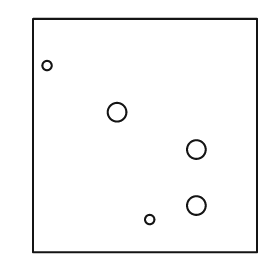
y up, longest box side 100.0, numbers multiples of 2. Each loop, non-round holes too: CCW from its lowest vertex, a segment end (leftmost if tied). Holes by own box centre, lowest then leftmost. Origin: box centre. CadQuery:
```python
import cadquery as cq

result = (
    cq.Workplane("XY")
    .moveTo(-48.0, -50.0)
    .lineTo(48.0, -50.0)
    .lineTo(48.0, 50.0)
    .lineTo(-48.0, 50.0)
    .close()
    .moveTo(2.0, -36.0)
    .circle(2.0)
    .moveTo(22.0, -30.0)
    .circle(4.0)
    .moveTo(22.0, -6.0)
    .circle(4.0)
    .moveTo(-12.0, 10.0)
    .circle(4.0)
    .moveTo(-42.0, 30.0)
    .circle(2.0)
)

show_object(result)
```